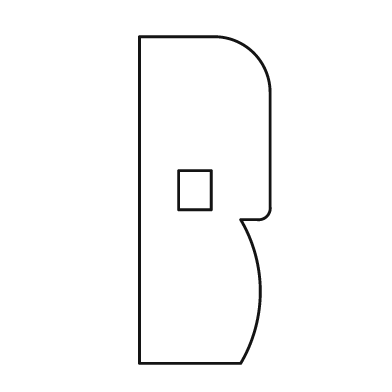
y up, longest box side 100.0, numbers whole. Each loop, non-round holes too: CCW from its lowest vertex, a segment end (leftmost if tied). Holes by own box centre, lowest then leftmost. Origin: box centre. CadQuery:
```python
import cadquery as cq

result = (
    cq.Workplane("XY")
    .moveTo(-20.0, -50.0)
    .lineTo(11.0, -50.0)
    .threePointArc((17.0, -28.0), (11.0, -6.0))
    .lineTo(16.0, -6.0)
    .threePointArc((19.0, -5.0), (20.0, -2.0))
    .lineTo(20.0, 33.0)
    .threePointArc((15.0, 45.0), (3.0, 50.0))
    .lineTo(-20.0, 50.0)
    .close()
    .moveTo(-8.0, -3.0)
    .lineTo(2.0, -3.0)
    .lineTo(2.0, 9.0)
    .lineTo(-8.0, 9.0)
    .close()
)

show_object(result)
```